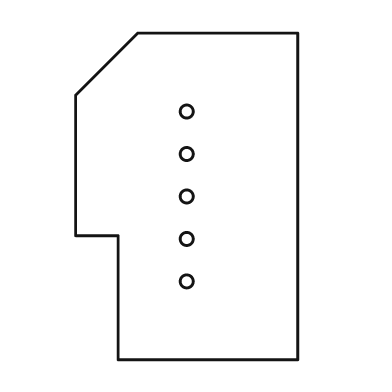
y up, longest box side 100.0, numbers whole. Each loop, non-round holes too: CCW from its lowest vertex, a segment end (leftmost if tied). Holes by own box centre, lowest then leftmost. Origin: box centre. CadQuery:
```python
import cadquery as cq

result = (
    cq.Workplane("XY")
    .moveTo(-21.0, -50.0)
    .lineTo(34.0, -50.0)
    .lineTo(34.0, 50.0)
    .lineTo(-15.0, 50.0)
    .lineTo(-34.0, 31.0)
    .lineTo(-34.0, -12.0)
    .lineTo(-21.0, -12.0)
    .close()
    .moveTo(0.0, -26.0)
    .circle(2.0)
    .moveTo(0.0, -13.0)
    .circle(2.0)
    .moveTo(0.0, 0.0)
    .circle(2.0)
    .moveTo(0.0, 13.0)
    .circle(2.0)
    .moveTo(0.0, 26.0)
    .circle(2.0)
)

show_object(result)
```